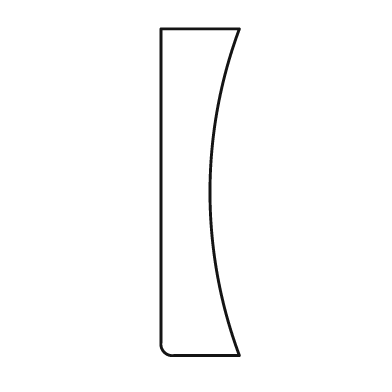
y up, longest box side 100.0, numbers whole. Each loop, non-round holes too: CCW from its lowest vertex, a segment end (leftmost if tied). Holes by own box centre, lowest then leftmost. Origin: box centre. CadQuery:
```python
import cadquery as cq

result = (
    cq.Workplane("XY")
    .moveTo(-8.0, -50.0)
    .lineTo(12.0, -50.0)
    .threePointArc((3.0, 0.0), (12.0, 50.0))
    .lineTo(-12.0, 50.0)
    .lineTo(-12.0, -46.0)
    .threePointArc((-11.0, -49.0), (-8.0, -50.0))
    .close()
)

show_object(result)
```